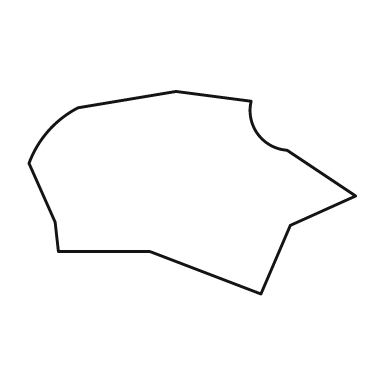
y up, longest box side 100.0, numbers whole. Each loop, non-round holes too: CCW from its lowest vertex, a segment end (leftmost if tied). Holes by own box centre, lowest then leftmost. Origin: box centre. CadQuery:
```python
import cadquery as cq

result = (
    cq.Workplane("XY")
    .moveTo(21.0, -31.0)
    .lineTo(30.0, -10.0)
    .lineTo(50.0, -1.0)
    .lineTo(29.0, 13.0)
    .threePointArc((20.0, 18.0), (18.0, 28.0))
    .lineTo(-5.0, 31.0)
    .lineTo(-35.0, 26.0)
    .threePointArc((-44.0, 19.0), (-50.0, 9.0))
    .lineTo(-42.0, -9.0)
    .lineTo(-41.0, -18.0)
    .lineTo(-13.0, -18.0)
    .close()
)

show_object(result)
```